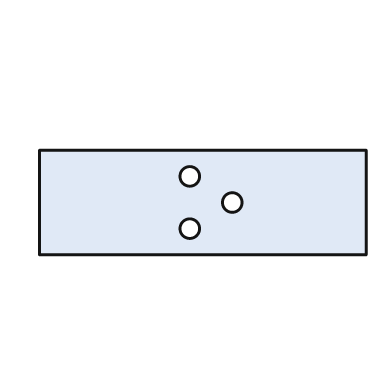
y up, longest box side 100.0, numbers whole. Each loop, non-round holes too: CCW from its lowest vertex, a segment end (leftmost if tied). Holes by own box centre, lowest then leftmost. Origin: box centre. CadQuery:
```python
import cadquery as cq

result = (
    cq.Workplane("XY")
    .moveTo(-50.0, -16.0)
    .lineTo(50.0, -16.0)
    .lineTo(50.0, 16.0)
    .lineTo(-50.0, 16.0)
    .close()
    .moveTo(-4.0, -8.0)
    .circle(3.0)
    .moveTo(9.0, 0.0)
    .circle(3.0)
    .moveTo(-4.0, 8.0)
    .circle(3.0)
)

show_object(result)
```